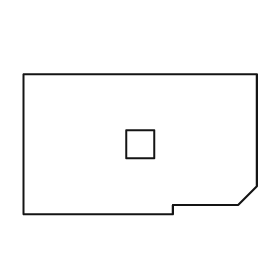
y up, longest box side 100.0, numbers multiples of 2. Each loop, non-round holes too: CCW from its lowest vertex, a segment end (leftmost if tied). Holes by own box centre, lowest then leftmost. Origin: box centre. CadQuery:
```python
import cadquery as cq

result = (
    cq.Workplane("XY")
    .moveTo(-50.0, -30.0)
    .lineTo(14.0, -30.0)
    .lineTo(14.0, -26.0)
    .lineTo(42.0, -26.0)
    .lineTo(50.0, -18.0)
    .lineTo(50.0, 30.0)
    .lineTo(-50.0, 30.0)
    .close()
    .moveTo(-6.0, -6.0)
    .lineTo(6.0, -6.0)
    .lineTo(6.0, 6.0)
    .lineTo(-6.0, 6.0)
    .close()
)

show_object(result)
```